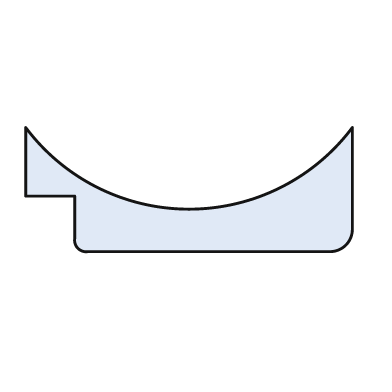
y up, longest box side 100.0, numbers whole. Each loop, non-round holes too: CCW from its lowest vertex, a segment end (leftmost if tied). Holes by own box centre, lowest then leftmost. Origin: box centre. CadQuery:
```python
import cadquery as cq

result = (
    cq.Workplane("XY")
    .moveTo(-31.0, -19.0)
    .lineTo(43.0, -19.0)
    .threePointArc((48.0, -17.0), (50.0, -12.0))
    .lineTo(50.0, 19.0)
    .threePointArc((0.0, -6.0), (-50.0, 19.0))
    .lineTo(-50.0, -2.0)
    .lineTo(-35.0, -2.0)
    .lineTo(-35.0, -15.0)
    .threePointArc((-34.0, -18.0), (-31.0, -19.0))
    .close()
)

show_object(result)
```